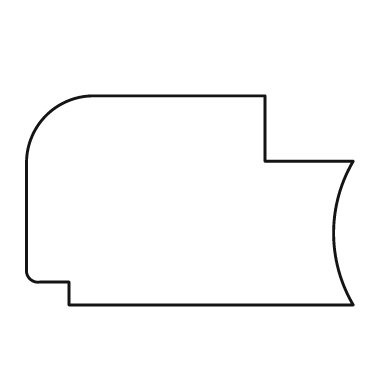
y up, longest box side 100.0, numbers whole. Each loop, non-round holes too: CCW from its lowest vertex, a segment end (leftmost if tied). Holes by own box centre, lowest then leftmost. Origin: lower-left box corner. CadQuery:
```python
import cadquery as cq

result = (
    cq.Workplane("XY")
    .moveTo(13.0, 0.0)
    .lineTo(100.0, 0.0)
    .threePointArc((94.0, 22.0), (100.0, 44.0))
    .lineTo(73.0, 44.0)
    .lineTo(73.0, 64.0)
    .lineTo(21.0, 64.0)
    .threePointArc((6.0, 58.0), (0.0, 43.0))
    .lineTo(0.0, 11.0)
    .threePointArc((1.0, 8.0), (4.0, 7.0))
    .lineTo(13.0, 7.0)
    .close()
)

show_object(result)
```